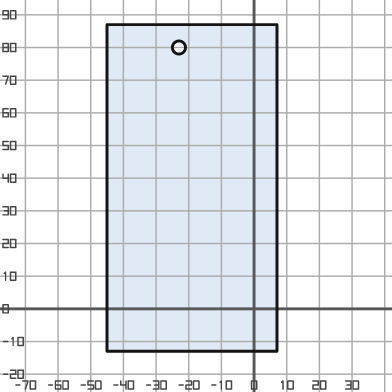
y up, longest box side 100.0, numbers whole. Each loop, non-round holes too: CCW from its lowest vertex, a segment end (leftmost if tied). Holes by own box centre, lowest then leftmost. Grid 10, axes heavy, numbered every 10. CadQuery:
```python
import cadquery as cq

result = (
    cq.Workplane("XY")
    .moveTo(-45.0, -13.0)
    .lineTo(7.0, -13.0)
    .lineTo(7.0, 87.0)
    .lineTo(-45.0, 87.0)
    .close()
    .moveTo(-23.0, 80.0)
    .circle(2.0)
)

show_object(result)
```